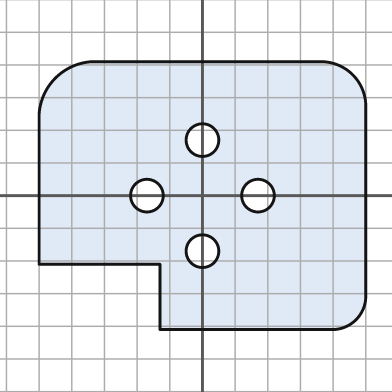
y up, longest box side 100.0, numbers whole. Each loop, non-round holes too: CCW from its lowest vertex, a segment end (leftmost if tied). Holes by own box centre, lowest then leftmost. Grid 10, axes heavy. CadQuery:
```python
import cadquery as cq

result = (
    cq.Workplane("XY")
    .moveTo(-13.0, -41.0)
    .lineTo(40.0, -41.0)
    .threePointArc((47.0, -38.0), (50.0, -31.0))
    .lineTo(50.0, 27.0)
    .threePointArc((46.0, 37.0), (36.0, 41.0))
    .lineTo(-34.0, 41.0)
    .threePointArc((-45.0, 36.0), (-50.0, 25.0))
    .lineTo(-50.0, -21.0)
    .lineTo(-13.0, -21.0)
    .close()
    .moveTo(0.0, -17.0)
    .circle(5.0)
    .moveTo(-17.0, 0.0)
    .circle(5.0)
    .moveTo(17.0, 0.0)
    .circle(5.0)
    .moveTo(0.0, 17.0)
    .circle(5.0)
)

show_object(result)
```